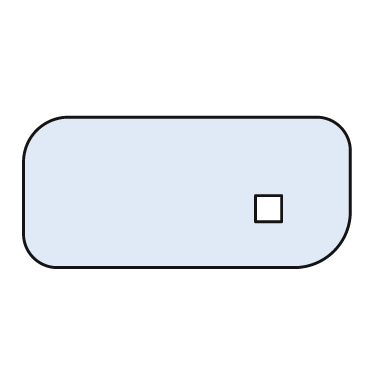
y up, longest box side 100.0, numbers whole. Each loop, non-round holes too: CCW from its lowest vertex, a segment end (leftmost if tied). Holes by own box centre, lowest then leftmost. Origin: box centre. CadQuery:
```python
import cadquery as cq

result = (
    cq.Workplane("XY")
    .moveTo(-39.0, -23.0)
    .lineTo(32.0, -23.0)
    .threePointArc((45.0, -18.0), (50.0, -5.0))
    .lineTo(50.0, 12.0)
    .threePointArc((47.0, 20.0), (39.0, 23.0))
    .lineTo(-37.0, 23.0)
    .threePointArc((-46.0, 19.0), (-50.0, 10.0))
    .lineTo(-50.0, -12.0)
    .threePointArc((-47.0, -20.0), (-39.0, -23.0))
    .close()
    .moveTo(21.0, -9.0)
    .lineTo(29.0, -9.0)
    .lineTo(29.0, -1.0)
    .lineTo(21.0, -1.0)
    .close()
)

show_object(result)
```